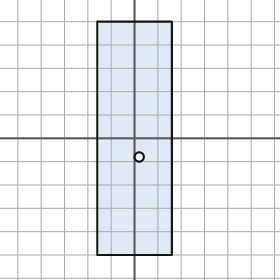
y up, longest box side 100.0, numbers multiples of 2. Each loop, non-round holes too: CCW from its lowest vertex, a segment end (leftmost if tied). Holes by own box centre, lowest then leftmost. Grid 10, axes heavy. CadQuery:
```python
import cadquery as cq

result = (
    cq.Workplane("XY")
    .moveTo(-16.0, -50.0)
    .lineTo(16.0, -50.0)
    .lineTo(16.0, 50.0)
    .lineTo(-16.0, 50.0)
    .close()
    .moveTo(2.0, -8.0)
    .circle(2.0)
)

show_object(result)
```